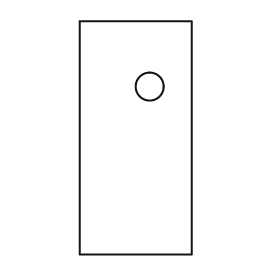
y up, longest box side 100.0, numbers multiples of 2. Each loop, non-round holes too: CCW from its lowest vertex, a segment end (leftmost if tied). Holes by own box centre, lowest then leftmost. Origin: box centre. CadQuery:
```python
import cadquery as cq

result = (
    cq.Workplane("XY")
    .moveTo(-24.0, -50.0)
    .lineTo(24.0, -50.0)
    .lineTo(24.0, 50.0)
    .lineTo(-24.0, 50.0)
    .close()
    .moveTo(6.0, 22.0)
    .circle(6.0)
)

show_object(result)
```